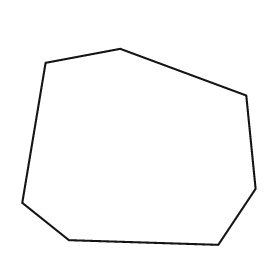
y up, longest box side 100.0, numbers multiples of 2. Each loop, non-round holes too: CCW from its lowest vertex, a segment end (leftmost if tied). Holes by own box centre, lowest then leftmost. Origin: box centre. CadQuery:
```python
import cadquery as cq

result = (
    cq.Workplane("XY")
    .moveTo(34.0, -42.0)
    .lineTo(50.0, -18.0)
    .lineTo(46.0, 22.0)
    .lineTo(-8.0, 42.0)
    .lineTo(-40.0, 36.0)
    .lineTo(-50.0, -24.0)
    .lineTo(-30.0, -40.0)
    .close()
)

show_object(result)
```